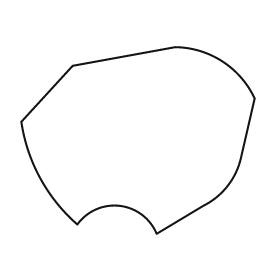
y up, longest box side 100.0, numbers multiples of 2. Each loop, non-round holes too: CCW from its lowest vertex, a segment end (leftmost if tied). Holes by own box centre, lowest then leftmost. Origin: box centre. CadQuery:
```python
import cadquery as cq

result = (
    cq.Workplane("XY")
    .moveTo(8.0, -40.0)
    .lineTo(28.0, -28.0)
    .threePointArc((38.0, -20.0), (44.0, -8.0))
    .lineTo(50.0, 18.0)
    .threePointArc((36.0, 34.0), (16.0, 40.0))
    .lineTo(-28.0, 32.0)
    .lineTo(-50.0, 8.0)
    .threePointArc((-42.0, -16.0), (-26.0, -36.0))
    .threePointArc((-8.0, -28.0), (8.0, -40.0))
    .close()
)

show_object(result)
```